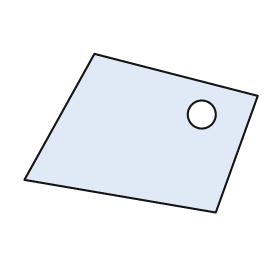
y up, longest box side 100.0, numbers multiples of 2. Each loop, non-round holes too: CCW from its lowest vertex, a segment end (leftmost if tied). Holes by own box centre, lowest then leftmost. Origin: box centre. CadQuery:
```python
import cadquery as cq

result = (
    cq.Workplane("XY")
    .moveTo(32.0, -34.0)
    .lineTo(50.0, 16.0)
    .lineTo(-20.0, 34.0)
    .lineTo(-50.0, -20.0)
    .close()
    .moveTo(26.0, 8.0)
    .circle(6.0)
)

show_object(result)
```